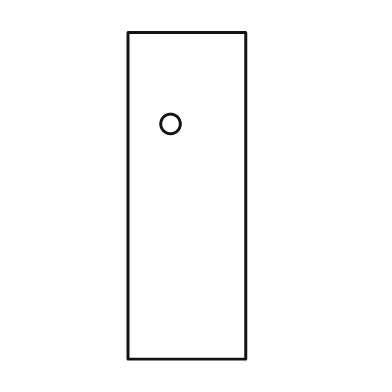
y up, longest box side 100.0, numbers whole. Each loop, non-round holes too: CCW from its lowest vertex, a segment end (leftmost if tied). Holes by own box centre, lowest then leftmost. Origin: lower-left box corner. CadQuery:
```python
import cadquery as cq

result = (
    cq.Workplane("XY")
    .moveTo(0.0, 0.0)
    .lineTo(36.0, 0.0)
    .lineTo(36.0, 100.0)
    .lineTo(0.0, 100.0)
    .close()
    .moveTo(13.0, 72.0)
    .circle(3.0)
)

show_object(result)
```